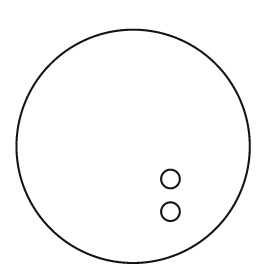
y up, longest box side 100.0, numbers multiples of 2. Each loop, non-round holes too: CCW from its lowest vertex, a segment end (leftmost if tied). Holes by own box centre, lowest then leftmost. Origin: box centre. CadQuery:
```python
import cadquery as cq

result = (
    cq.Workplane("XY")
    .moveTo(0.0, 0.0)
    .circle(50.0)
    .moveTo(16.0, -28.0)
    .circle(4.0)
    .moveTo(16.0, -14.0)
    .circle(4.0)
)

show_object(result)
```